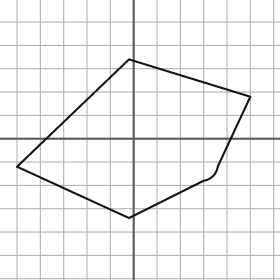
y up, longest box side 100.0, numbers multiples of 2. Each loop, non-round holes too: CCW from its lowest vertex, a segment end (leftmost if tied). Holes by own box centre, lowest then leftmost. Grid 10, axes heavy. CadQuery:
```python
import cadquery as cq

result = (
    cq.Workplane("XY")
    .moveTo(-2.0, -34.0)
    .lineTo(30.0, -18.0)
    .threePointArc((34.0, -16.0), (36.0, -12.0))
    .lineTo(50.0, 18.0)
    .lineTo(-2.0, 34.0)
    .lineTo(-50.0, -12.0)
    .close()
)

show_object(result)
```